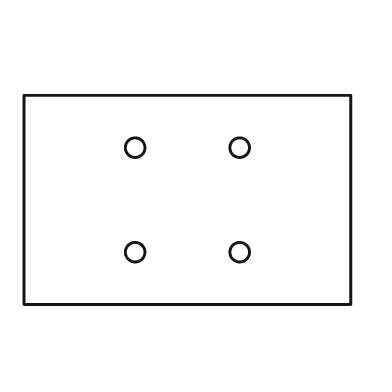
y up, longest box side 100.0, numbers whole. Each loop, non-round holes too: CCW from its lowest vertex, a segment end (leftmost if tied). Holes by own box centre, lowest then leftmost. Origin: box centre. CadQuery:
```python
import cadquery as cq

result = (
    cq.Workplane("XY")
    .moveTo(-50.0, -32.0)
    .lineTo(50.0, -32.0)
    .lineTo(50.0, 32.0)
    .lineTo(-50.0, 32.0)
    .close()
    .moveTo(-16.0, -16.0)
    .circle(3.0)
    .moveTo(16.0, -16.0)
    .circle(3.0)
    .moveTo(-16.0, 16.0)
    .circle(3.0)
    .moveTo(16.0, 16.0)
    .circle(3.0)
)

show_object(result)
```